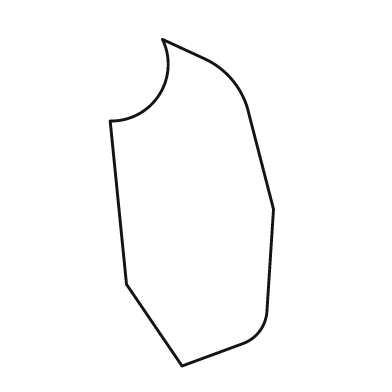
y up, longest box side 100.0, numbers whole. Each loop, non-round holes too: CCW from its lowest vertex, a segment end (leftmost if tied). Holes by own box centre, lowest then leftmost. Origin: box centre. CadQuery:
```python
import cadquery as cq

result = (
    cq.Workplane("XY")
    .moveTo(-3.0, -50.0)
    .lineTo(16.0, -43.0)
    .threePointArc((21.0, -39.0), (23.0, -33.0))
    .lineTo(25.0, -2.0)
    .lineTo(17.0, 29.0)
    .threePointArc((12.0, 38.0), (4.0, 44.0))
    .lineTo(-9.0, 50.0)
    .threePointArc((-10.0, 33.0), (-25.0, 25.0))
    .lineTo(-20.0, -25.0)
    .close()
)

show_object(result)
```